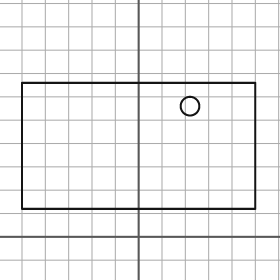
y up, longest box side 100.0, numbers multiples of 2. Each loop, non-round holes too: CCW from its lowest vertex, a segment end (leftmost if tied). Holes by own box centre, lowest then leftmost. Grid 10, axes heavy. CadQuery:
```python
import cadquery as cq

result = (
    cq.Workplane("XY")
    .moveTo(-50.0, 12.0)
    .lineTo(50.0, 12.0)
    .lineTo(50.0, 66.0)
    .lineTo(-50.0, 66.0)
    .close()
    .moveTo(22.0, 56.0)
    .circle(4.0)
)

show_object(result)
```